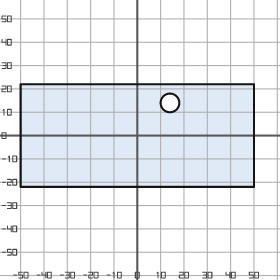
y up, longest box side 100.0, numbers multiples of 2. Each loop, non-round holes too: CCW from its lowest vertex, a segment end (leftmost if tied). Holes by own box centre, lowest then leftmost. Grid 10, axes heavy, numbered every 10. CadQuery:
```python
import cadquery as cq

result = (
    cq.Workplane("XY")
    .moveTo(-50.0, -22.0)
    .lineTo(50.0, -22.0)
    .lineTo(50.0, 22.0)
    .lineTo(-50.0, 22.0)
    .close()
    .moveTo(14.0, 14.0)
    .circle(4.0)
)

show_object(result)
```